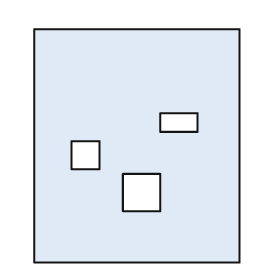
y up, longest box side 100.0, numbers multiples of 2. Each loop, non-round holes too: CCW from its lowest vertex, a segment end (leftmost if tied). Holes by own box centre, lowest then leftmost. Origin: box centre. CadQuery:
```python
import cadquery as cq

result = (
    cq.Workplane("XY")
    .moveTo(-44.0, -50.0)
    .lineTo(44.0, -50.0)
    .lineTo(44.0, 50.0)
    .lineTo(-44.0, 50.0)
    .close()
    .moveTo(-6.0, -28.0)
    .lineTo(10.0, -28.0)
    .lineTo(10.0, -12.0)
    .lineTo(-6.0, -12.0)
    .close()
    .moveTo(-28.0, -10.0)
    .lineTo(-16.0, -10.0)
    .lineTo(-16.0, 2.0)
    .lineTo(-28.0, 2.0)
    .close()
    .moveTo(10.0, 6.0)
    .lineTo(26.0, 6.0)
    .lineTo(26.0, 14.0)
    .lineTo(10.0, 14.0)
    .close()
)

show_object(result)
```